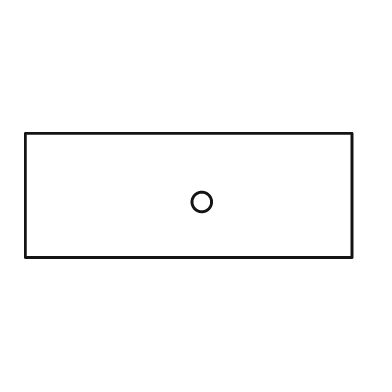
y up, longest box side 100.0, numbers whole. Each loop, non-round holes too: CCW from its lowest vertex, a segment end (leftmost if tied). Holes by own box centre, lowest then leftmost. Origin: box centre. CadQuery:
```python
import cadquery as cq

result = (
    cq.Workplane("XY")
    .moveTo(-50.0, -19.0)
    .lineTo(50.0, -19.0)
    .lineTo(50.0, 19.0)
    .lineTo(-50.0, 19.0)
    .close()
    .moveTo(4.0, -2.0)
    .circle(3.0)
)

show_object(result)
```